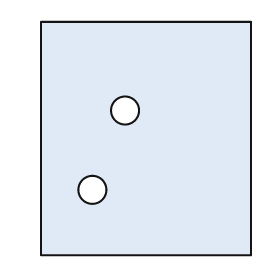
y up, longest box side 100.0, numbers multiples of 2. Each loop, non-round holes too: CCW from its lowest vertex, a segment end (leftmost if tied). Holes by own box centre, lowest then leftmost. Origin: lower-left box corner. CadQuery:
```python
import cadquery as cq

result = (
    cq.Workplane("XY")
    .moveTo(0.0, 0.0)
    .lineTo(90.0, 0.0)
    .lineTo(90.0, 100.0)
    .lineTo(0.0, 100.0)
    .close()
    .moveTo(22.0, 28.0)
    .circle(6.0)
    .moveTo(36.0, 62.0)
    .circle(6.0)
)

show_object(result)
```